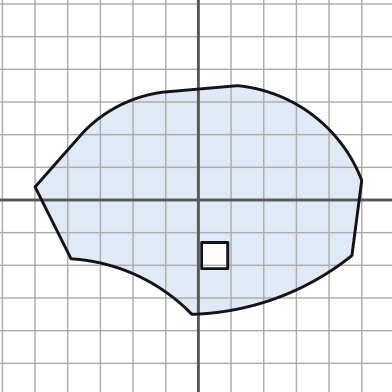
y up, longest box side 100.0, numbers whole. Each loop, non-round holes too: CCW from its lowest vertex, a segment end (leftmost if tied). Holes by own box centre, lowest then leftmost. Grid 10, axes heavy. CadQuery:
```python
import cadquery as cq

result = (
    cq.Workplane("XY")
    .moveTo(-2.0, -35.0)
    .threePointArc((24.0, -30.0), (47.0, -17.0))
    .lineTo(50.0, 6.0)
    .threePointArc((35.0, 26.0), (12.0, 35.0))
    .lineTo(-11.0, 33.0)
    .threePointArc((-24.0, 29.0), (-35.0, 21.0))
    .lineTo(-50.0, 4.0)
    .lineTo(-39.0, -18.0)
    .threePointArc((-19.0, -23.0), (-2.0, -35.0))
    .close()
    .moveTo(1.0, -21.0)
    .lineTo(9.0, -21.0)
    .lineTo(9.0, -13.0)
    .lineTo(1.0, -13.0)
    .close()
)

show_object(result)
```